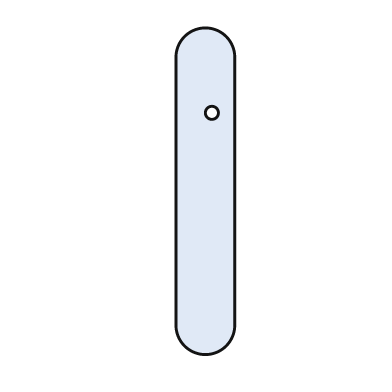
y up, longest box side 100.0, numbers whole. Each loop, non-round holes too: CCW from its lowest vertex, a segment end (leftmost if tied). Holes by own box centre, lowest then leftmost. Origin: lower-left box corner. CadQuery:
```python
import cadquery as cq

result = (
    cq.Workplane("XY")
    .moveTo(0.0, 9.0)
    .threePointArc((9.0, 0.0), (18.0, 9.0))
    .lineTo(18.0, 91.0)
    .threePointArc((9.0, 100.0), (0.0, 91.0))
    .close()
    .moveTo(11.0, 74.0)
    .circle(2.0)
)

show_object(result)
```